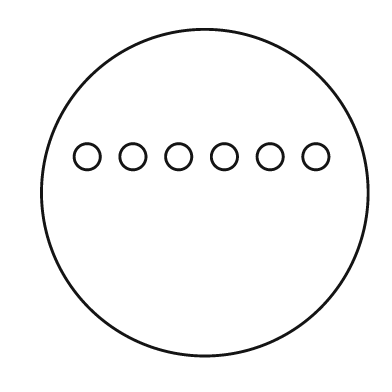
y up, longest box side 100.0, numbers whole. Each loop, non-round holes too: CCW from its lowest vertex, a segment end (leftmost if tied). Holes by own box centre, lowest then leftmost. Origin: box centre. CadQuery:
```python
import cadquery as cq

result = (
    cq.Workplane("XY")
    .moveTo(0.0, 0.0)
    .circle(50.0)
    .moveTo(-36.0, 11.0)
    .circle(4.0)
    .moveTo(-22.0, 11.0)
    .circle(4.0)
    .moveTo(-8.0, 11.0)
    .circle(4.0)
    .moveTo(6.0, 11.0)
    .circle(4.0)
    .moveTo(20.0, 11.0)
    .circle(4.0)
    .moveTo(34.0, 11.0)
    .circle(4.0)
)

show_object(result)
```